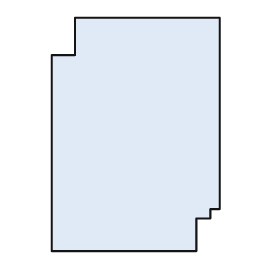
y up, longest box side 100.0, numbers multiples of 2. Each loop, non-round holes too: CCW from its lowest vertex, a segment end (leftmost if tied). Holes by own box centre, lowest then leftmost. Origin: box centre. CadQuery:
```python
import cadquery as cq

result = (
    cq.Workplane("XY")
    .moveTo(-36.0, -50.0)
    .lineTo(26.0, -50.0)
    .lineTo(26.0, -36.0)
    .lineTo(32.0, -36.0)
    .lineTo(32.0, -32.0)
    .lineTo(36.0, -32.0)
    .lineTo(36.0, 50.0)
    .lineTo(-26.0, 50.0)
    .lineTo(-26.0, 34.0)
    .lineTo(-36.0, 34.0)
    .close()
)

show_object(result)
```